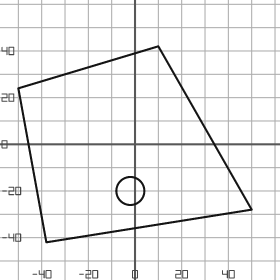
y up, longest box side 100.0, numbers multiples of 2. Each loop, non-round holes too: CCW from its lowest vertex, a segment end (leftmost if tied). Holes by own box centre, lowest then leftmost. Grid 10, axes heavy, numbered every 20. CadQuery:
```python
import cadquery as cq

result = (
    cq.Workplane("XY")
    .moveTo(-38.0, -42.0)
    .lineTo(50.0, -28.0)
    .lineTo(10.0, 42.0)
    .lineTo(-50.0, 24.0)
    .close()
    .moveTo(-2.0, -20.0)
    .circle(6.0)
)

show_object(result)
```